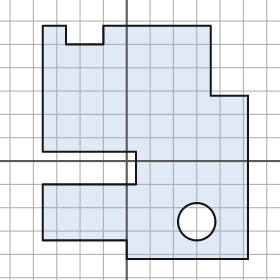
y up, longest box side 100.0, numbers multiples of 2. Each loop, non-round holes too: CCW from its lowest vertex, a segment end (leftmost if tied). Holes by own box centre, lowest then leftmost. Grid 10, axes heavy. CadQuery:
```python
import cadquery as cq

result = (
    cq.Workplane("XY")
    .moveTo(0.0, -42.0)
    .lineTo(52.0, -42.0)
    .lineTo(52.0, 28.0)
    .lineTo(36.0, 28.0)
    .lineTo(36.0, 58.0)
    .lineTo(-10.0, 58.0)
    .lineTo(-10.0, 50.0)
    .lineTo(-26.0, 50.0)
    .lineTo(-26.0, 58.0)
    .lineTo(-36.0, 58.0)
    .lineTo(-36.0, 4.0)
    .lineTo(4.0, 4.0)
    .lineTo(4.0, -10.0)
    .lineTo(-36.0, -10.0)
    .lineTo(-36.0, -34.0)
    .lineTo(0.0, -34.0)
    .close()
    .moveTo(30.0, -26.0)
    .circle(8.0)
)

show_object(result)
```